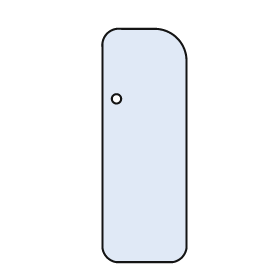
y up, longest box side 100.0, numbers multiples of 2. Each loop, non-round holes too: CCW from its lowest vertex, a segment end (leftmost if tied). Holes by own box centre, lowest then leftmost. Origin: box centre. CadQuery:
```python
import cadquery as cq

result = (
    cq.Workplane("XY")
    .moveTo(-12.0, -50.0)
    .lineTo(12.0, -50.0)
    .threePointArc((16.0, -48.0), (18.0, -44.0))
    .lineTo(18.0, 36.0)
    .threePointArc((14.0, 46.0), (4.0, 50.0))
    .lineTo(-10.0, 50.0)
    .threePointArc((-16.0, 48.0), (-18.0, 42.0))
    .lineTo(-18.0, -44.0)
    .threePointArc((-16.0, -48.0), (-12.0, -50.0))
    .close()
    .moveTo(-12.0, 20.0)
    .circle(2.0)
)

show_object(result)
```